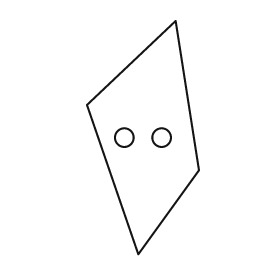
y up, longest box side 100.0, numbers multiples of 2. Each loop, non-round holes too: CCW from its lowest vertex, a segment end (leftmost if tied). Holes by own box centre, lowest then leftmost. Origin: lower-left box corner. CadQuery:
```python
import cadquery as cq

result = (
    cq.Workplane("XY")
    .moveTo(22.0, 0.0)
    .lineTo(48.0, 36.0)
    .lineTo(38.0, 100.0)
    .lineTo(0.0, 64.0)
    .close()
    .moveTo(16.0, 50.0)
    .circle(4.0)
    .moveTo(32.0, 50.0)
    .circle(4.0)
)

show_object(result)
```